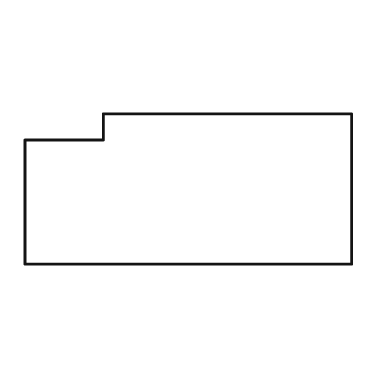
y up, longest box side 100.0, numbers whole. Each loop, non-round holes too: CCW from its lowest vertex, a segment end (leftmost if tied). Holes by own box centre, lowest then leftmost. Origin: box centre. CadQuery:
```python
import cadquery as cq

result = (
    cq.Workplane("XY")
    .moveTo(-50.0, -23.0)
    .lineTo(50.0, -23.0)
    .lineTo(50.0, 23.0)
    .lineTo(-26.0, 23.0)
    .lineTo(-26.0, 15.0)
    .lineTo(-50.0, 15.0)
    .close()
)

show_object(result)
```